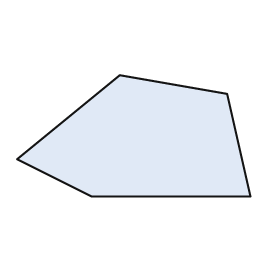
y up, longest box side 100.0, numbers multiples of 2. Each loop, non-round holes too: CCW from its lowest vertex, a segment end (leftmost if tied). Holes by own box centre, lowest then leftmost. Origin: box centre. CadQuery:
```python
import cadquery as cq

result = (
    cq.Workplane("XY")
    .moveTo(-18.0, -26.0)
    .lineTo(50.0, -26.0)
    .lineTo(40.0, 18.0)
    .lineTo(-6.0, 26.0)
    .lineTo(-50.0, -10.0)
    .close()
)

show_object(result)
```